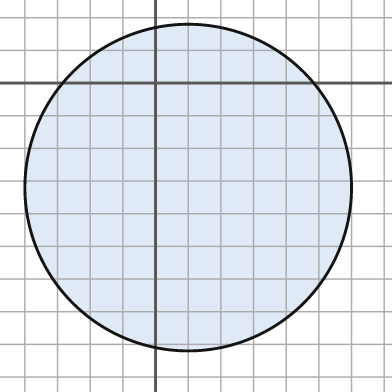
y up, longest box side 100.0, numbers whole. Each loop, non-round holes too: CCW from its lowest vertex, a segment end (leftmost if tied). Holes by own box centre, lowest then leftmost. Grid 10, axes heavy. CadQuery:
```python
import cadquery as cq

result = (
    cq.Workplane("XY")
    .moveTo(10.0, -32.0)
    .circle(50.0)
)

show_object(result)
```